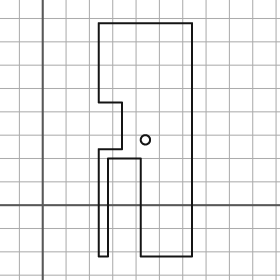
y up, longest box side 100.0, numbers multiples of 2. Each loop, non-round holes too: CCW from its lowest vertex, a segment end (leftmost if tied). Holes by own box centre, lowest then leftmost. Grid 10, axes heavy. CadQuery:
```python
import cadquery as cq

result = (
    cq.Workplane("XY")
    .moveTo(24.0, -22.0)
    .lineTo(28.0, -22.0)
    .lineTo(28.0, 20.0)
    .lineTo(42.0, 20.0)
    .lineTo(42.0, -22.0)
    .lineTo(64.0, -22.0)
    .lineTo(64.0, 78.0)
    .lineTo(24.0, 78.0)
    .lineTo(24.0, 44.0)
    .lineTo(34.0, 44.0)
    .lineTo(34.0, 24.0)
    .lineTo(24.0, 24.0)
    .close()
    .moveTo(44.0, 28.0)
    .circle(2.0)
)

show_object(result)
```